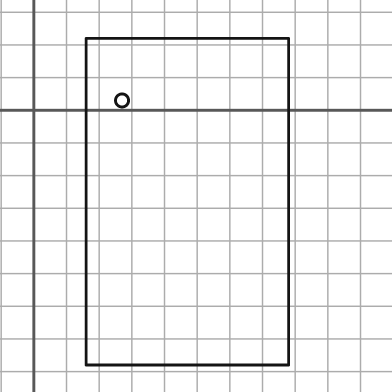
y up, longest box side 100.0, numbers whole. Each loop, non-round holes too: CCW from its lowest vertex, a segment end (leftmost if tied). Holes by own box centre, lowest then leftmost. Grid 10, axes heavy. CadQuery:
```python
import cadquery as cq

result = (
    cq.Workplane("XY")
    .moveTo(16.0, -78.0)
    .lineTo(78.0, -78.0)
    .lineTo(78.0, 22.0)
    .lineTo(16.0, 22.0)
    .close()
    .moveTo(27.0, 3.0)
    .circle(2.0)
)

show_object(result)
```